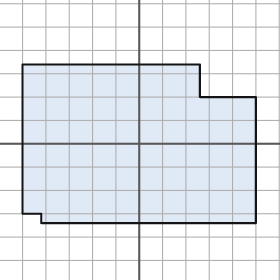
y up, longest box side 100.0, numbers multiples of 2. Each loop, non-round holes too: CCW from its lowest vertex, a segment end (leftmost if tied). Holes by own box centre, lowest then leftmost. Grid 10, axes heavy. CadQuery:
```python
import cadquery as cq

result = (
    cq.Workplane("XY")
    .moveTo(-42.0, -34.0)
    .lineTo(50.0, -34.0)
    .lineTo(50.0, 20.0)
    .lineTo(26.0, 20.0)
    .lineTo(26.0, 34.0)
    .lineTo(-50.0, 34.0)
    .lineTo(-50.0, -30.0)
    .lineTo(-42.0, -30.0)
    .close()
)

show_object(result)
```